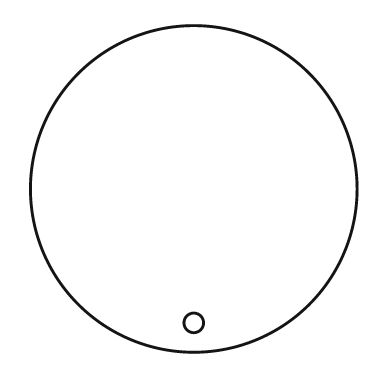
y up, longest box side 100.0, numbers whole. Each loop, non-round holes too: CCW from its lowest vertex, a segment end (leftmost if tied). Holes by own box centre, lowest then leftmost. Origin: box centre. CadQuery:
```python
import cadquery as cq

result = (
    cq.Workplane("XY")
    .moveTo(0.0, 0.0)
    .circle(50.0)
    .moveTo(0.0, -41.0)
    .circle(3.0)
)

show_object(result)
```